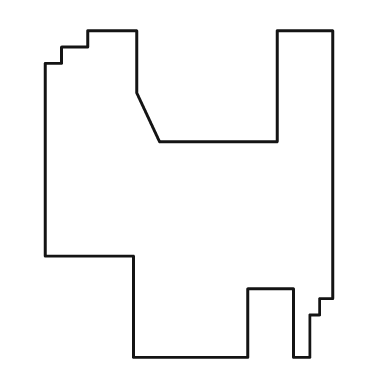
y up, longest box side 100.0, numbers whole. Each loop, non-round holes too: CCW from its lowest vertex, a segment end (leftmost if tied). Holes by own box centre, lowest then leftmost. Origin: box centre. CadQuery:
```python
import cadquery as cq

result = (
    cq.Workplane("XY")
    .moveTo(-17.0, -50.0)
    .lineTo(18.0, -50.0)
    .lineTo(18.0, -29.0)
    .lineTo(32.0, -29.0)
    .lineTo(32.0, -50.0)
    .lineTo(37.0, -50.0)
    .lineTo(37.0, -37.0)
    .lineTo(40.0, -37.0)
    .lineTo(40.0, -32.0)
    .lineTo(44.0, -32.0)
    .lineTo(44.0, 50.0)
    .lineTo(27.0, 50.0)
    .lineTo(27.0, 16.0)
    .lineTo(-9.0, 16.0)
    .lineTo(-16.0, 31.0)
    .lineTo(-16.0, 50.0)
    .lineTo(-31.0, 50.0)
    .lineTo(-31.0, 45.0)
    .lineTo(-39.0, 45.0)
    .lineTo(-39.0, 40.0)
    .lineTo(-44.0, 40.0)
    .lineTo(-44.0, -19.0)
    .lineTo(-17.0, -19.0)
    .close()
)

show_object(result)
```